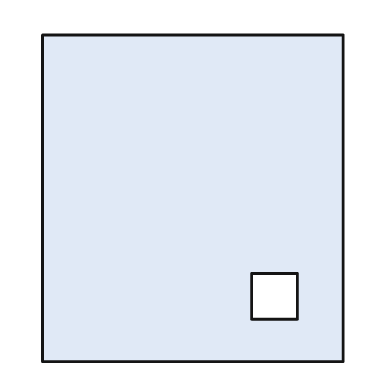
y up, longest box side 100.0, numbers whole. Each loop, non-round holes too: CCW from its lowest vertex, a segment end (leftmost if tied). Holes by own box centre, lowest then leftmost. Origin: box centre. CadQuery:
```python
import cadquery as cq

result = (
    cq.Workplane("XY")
    .moveTo(-46.0, -50.0)
    .lineTo(46.0, -50.0)
    .lineTo(46.0, 50.0)
    .lineTo(-46.0, 50.0)
    .close()
    .moveTo(18.0, -37.0)
    .lineTo(32.0, -37.0)
    .lineTo(32.0, -23.0)
    .lineTo(18.0, -23.0)
    .close()
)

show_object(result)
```